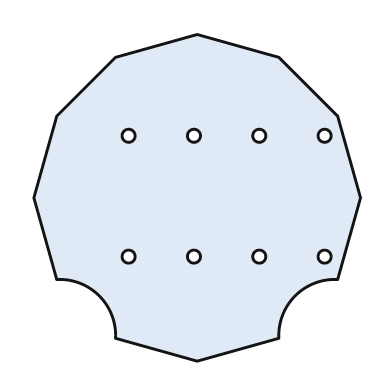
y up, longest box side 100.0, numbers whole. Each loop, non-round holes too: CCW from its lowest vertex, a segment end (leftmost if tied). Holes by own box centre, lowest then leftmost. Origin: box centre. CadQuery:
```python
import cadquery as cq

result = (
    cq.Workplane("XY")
    .moveTo(0.0, -50.0)
    .lineTo(25.0, -43.0)
    .threePointArc((30.0, -30.0), (43.0, -25.0))
    .lineTo(50.0, 0.0)
    .lineTo(43.0, 25.0)
    .lineTo(25.0, 43.0)
    .lineTo(0.0, 50.0)
    .lineTo(-25.0, 43.0)
    .lineTo(-43.0, 25.0)
    .lineTo(-50.0, 0.0)
    .lineTo(-43.0, -25.0)
    .threePointArc((-30.0, -30.0), (-25.0, -43.0))
    .close()
    .moveTo(-21.0, -18.0)
    .circle(2.0)
    .moveTo(-1.0, -18.0)
    .circle(2.0)
    .moveTo(19.0, -18.0)
    .circle(2.0)
    .moveTo(39.0, -18.0)
    .circle(2.0)
    .moveTo(-21.0, 19.0)
    .circle(2.0)
    .moveTo(-1.0, 19.0)
    .circle(2.0)
    .moveTo(19.0, 19.0)
    .circle(2.0)
    .moveTo(39.0, 19.0)
    .circle(2.0)
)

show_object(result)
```